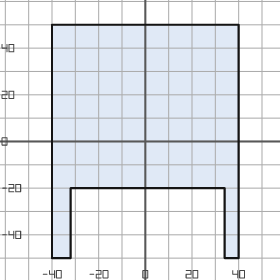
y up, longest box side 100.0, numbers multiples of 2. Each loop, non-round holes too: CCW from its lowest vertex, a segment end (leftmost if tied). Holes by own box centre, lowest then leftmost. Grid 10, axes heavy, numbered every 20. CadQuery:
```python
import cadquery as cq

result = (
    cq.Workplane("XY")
    .moveTo(-40.0, -50.0)
    .lineTo(-32.0, -50.0)
    .lineTo(-32.0, -20.0)
    .lineTo(34.0, -20.0)
    .lineTo(34.0, -50.0)
    .lineTo(40.0, -50.0)
    .lineTo(40.0, 50.0)
    .lineTo(-40.0, 50.0)
    .close()
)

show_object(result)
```